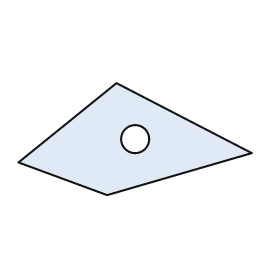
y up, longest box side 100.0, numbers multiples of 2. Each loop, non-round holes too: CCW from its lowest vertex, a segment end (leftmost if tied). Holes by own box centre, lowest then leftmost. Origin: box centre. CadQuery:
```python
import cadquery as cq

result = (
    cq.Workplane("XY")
    .moveTo(-12.0, -24.0)
    .lineTo(50.0, -6.0)
    .lineTo(-8.0, 24.0)
    .lineTo(-50.0, -10.0)
    .close()
    .moveTo(0.0, 0.0)
    .circle(6.0)
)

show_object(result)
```